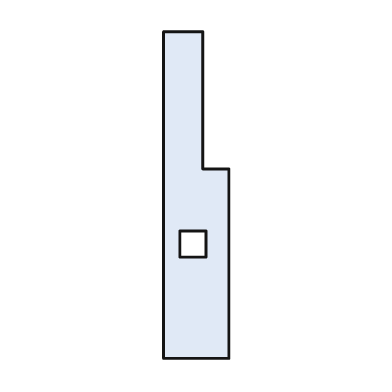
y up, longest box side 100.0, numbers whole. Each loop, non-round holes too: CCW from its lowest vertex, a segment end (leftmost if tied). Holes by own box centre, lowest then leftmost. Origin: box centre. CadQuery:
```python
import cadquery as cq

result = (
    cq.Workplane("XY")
    .moveTo(-10.0, -50.0)
    .lineTo(10.0, -50.0)
    .lineTo(10.0, 8.0)
    .lineTo(2.0, 8.0)
    .lineTo(2.0, 50.0)
    .lineTo(-10.0, 50.0)
    .close()
    .moveTo(-5.0, -19.0)
    .lineTo(3.0, -19.0)
    .lineTo(3.0, -11.0)
    .lineTo(-5.0, -11.0)
    .close()
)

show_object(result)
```